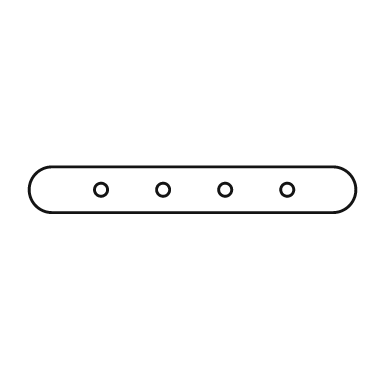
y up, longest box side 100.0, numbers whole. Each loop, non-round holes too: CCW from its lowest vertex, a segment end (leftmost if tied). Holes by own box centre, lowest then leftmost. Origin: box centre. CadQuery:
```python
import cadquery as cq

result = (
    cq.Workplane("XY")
    .moveTo(-43.0, -7.0)
    .lineTo(43.0, -7.0)
    .threePointArc((50.0, 0.0), (43.0, 7.0))
    .lineTo(-43.0, 7.0)
    .threePointArc((-50.0, 0.0), (-43.0, -7.0))
    .close()
    .moveTo(-28.0, 0.0)
    .circle(2.0)
    .moveTo(-9.0, 0.0)
    .circle(2.0)
    .moveTo(10.0, 0.0)
    .circle(2.0)
    .moveTo(29.0, 0.0)
    .circle(2.0)
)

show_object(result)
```